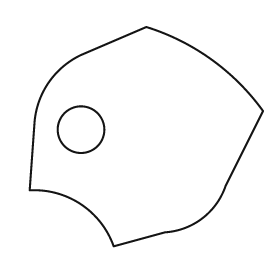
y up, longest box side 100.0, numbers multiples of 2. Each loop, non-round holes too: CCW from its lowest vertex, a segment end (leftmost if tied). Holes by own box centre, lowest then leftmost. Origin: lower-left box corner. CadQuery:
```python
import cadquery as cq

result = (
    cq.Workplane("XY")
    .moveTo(36.0, 0.0)
    .lineTo(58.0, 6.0)
    .threePointArc((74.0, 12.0), (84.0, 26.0))
    .lineTo(100.0, 58.0)
    .threePointArc((78.0, 80.0), (50.0, 94.0))
    .lineTo(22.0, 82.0)
    .threePointArc((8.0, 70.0), (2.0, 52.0))
    .lineTo(0.0, 24.0)
    .threePointArc((22.0, 18.0), (36.0, 0.0))
    .close()
    .moveTo(22.0, 50.0)
    .circle(10.0)
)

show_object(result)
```